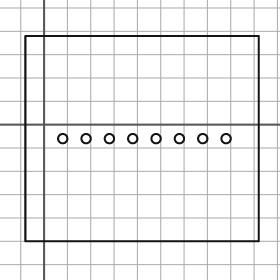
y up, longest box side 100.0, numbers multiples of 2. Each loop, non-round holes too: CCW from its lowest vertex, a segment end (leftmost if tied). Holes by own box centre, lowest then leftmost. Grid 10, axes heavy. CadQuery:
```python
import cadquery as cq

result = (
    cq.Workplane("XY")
    .moveTo(-8.0, -50.0)
    .lineTo(92.0, -50.0)
    .lineTo(92.0, 38.0)
    .lineTo(-8.0, 38.0)
    .close()
    .moveTo(8.0, -6.0)
    .circle(2.0)
    .moveTo(18.0, -6.0)
    .circle(2.0)
    .moveTo(28.0, -6.0)
    .circle(2.0)
    .moveTo(38.0, -6.0)
    .circle(2.0)
    .moveTo(48.0, -6.0)
    .circle(2.0)
    .moveTo(58.0, -6.0)
    .circle(2.0)
    .moveTo(68.0, -6.0)
    .circle(2.0)
    .moveTo(78.0, -6.0)
    .circle(2.0)
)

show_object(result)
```